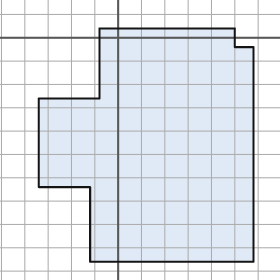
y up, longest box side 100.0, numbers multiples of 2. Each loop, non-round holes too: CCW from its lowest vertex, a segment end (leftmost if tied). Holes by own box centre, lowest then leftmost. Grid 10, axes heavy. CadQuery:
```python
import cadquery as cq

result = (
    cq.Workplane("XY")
    .moveTo(-12.0, -96.0)
    .lineTo(58.0, -96.0)
    .lineTo(58.0, -4.0)
    .lineTo(50.0, -4.0)
    .lineTo(50.0, 4.0)
    .lineTo(-8.0, 4.0)
    .lineTo(-8.0, -26.0)
    .lineTo(-34.0, -26.0)
    .lineTo(-34.0, -64.0)
    .lineTo(-12.0, -64.0)
    .close()
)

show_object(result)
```